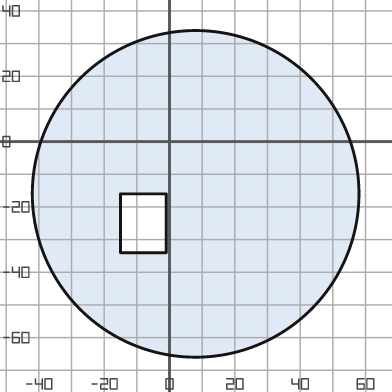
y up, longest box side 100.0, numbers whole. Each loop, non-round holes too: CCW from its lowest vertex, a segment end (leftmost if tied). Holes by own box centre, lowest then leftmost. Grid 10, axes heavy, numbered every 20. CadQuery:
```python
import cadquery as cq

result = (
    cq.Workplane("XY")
    .moveTo(8.0, -16.0)
    .circle(50.0)
    .moveTo(-15.0, -34.0)
    .lineTo(-1.0, -34.0)
    .lineTo(-1.0, -16.0)
    .lineTo(-15.0, -16.0)
    .close()
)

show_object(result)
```